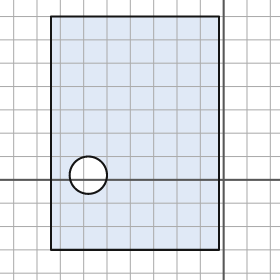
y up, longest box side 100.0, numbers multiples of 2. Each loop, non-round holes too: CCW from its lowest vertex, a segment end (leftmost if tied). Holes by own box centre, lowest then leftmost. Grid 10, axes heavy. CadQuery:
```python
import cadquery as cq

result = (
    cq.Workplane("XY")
    .moveTo(-74.0, -30.0)
    .lineTo(-2.0, -30.0)
    .lineTo(-2.0, 70.0)
    .lineTo(-74.0, 70.0)
    .close()
    .moveTo(-58.0, 2.0)
    .circle(8.0)
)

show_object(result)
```